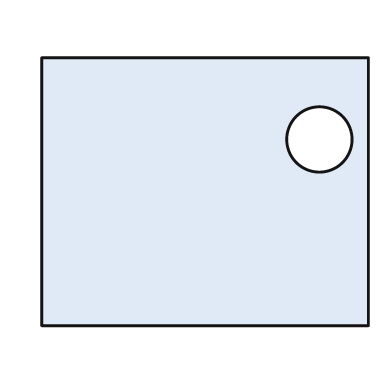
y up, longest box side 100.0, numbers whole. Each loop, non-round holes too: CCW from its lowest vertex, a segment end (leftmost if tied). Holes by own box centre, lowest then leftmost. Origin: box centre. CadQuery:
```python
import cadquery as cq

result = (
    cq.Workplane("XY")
    .moveTo(-50.0, -41.0)
    .lineTo(50.0, -41.0)
    .lineTo(50.0, 41.0)
    .lineTo(-50.0, 41.0)
    .close()
    .moveTo(35.0, 16.0)
    .circle(10.0)
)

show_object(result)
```